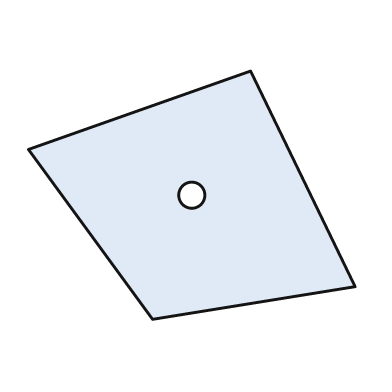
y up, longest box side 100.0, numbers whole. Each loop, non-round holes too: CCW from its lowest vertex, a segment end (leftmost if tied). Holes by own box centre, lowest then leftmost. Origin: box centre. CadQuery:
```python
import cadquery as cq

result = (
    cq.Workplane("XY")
    .moveTo(-12.0, -38.0)
    .lineTo(50.0, -28.0)
    .lineTo(18.0, 38.0)
    .lineTo(-50.0, 14.0)
    .close()
    .moveTo(0.0, 0.0)
    .circle(4.0)
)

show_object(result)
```